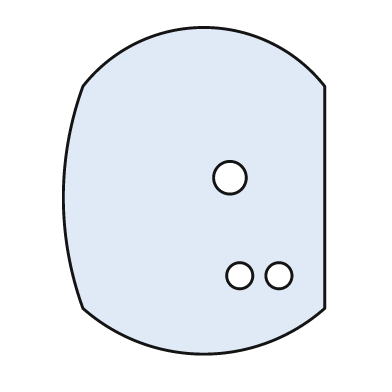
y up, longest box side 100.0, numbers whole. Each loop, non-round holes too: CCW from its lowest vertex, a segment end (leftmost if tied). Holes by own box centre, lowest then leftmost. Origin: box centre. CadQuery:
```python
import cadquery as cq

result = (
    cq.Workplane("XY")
    .moveTo(-34.0, -36.0)
    .threePointArc((3.0, -50.0), (40.0, -36.0))
    .lineTo(40.0, 32.0)
    .threePointArc((3.0, 50.0), (-34.0, 32.0))
    .threePointArc((-40.0, -2.0), (-34.0, -36.0))
    .close()
    .moveTo(14.0, -26.0)
    .circle(4.0)
    .moveTo(26.0, -26.0)
    .circle(4.0)
    .moveTo(11.0, 4.0)
    .circle(5.0)
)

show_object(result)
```